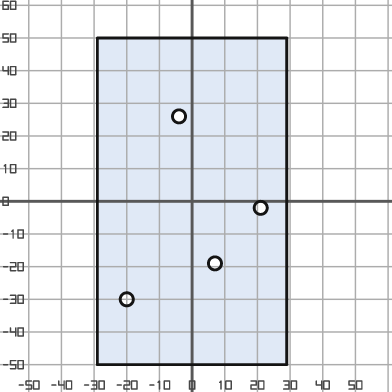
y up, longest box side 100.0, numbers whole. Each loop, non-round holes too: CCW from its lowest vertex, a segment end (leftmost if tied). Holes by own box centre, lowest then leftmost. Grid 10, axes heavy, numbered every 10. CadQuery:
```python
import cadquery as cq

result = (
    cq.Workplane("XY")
    .moveTo(-29.0, -50.0)
    .lineTo(29.0, -50.0)
    .lineTo(29.0, 50.0)
    .lineTo(-29.0, 50.0)
    .close()
    .moveTo(-20.0, -30.0)
    .circle(2.0)
    .moveTo(7.0, -19.0)
    .circle(2.0)
    .moveTo(21.0, -2.0)
    .circle(2.0)
    .moveTo(-4.0, 26.0)
    .circle(2.0)
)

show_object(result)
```